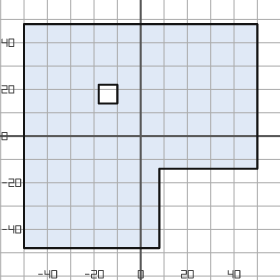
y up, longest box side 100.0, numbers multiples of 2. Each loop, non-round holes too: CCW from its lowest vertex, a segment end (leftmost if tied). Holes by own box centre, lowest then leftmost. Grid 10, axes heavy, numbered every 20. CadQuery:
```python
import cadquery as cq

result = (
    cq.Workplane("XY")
    .moveTo(-50.0, -48.0)
    .lineTo(8.0, -48.0)
    .lineTo(8.0, -14.0)
    .lineTo(50.0, -14.0)
    .lineTo(50.0, 48.0)
    .lineTo(-50.0, 48.0)
    .close()
    .moveTo(-18.0, 14.0)
    .lineTo(-10.0, 14.0)
    .lineTo(-10.0, 22.0)
    .lineTo(-18.0, 22.0)
    .close()
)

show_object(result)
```